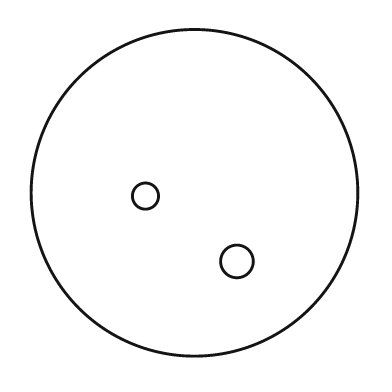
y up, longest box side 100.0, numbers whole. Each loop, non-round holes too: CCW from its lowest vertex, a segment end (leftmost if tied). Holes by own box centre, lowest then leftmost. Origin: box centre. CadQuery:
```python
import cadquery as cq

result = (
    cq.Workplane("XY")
    .moveTo(0.0, 0.0)
    .circle(50.0)
    .moveTo(13.0, -21.0)
    .circle(5.0)
    .moveTo(-15.0, -1.0)
    .circle(4.0)
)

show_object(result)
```